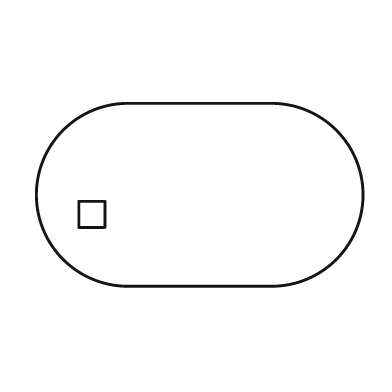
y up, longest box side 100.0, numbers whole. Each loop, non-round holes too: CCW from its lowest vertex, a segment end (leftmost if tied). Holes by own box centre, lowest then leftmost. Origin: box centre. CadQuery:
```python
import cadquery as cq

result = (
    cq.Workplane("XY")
    .moveTo(-22.0, -28.0)
    .lineTo(22.0, -28.0)
    .threePointArc((50.0, 0.0), (22.0, 28.0))
    .lineTo(-22.0, 28.0)
    .threePointArc((-50.0, 0.0), (-22.0, -28.0))
    .close()
    .moveTo(-37.0, -10.0)
    .lineTo(-29.0, -10.0)
    .lineTo(-29.0, -2.0)
    .lineTo(-37.0, -2.0)
    .close()
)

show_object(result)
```